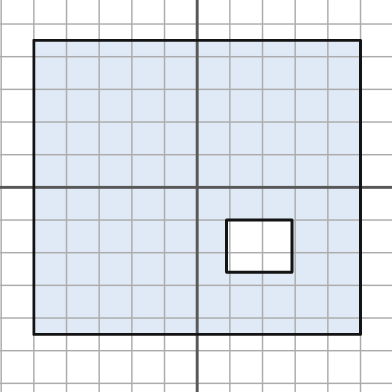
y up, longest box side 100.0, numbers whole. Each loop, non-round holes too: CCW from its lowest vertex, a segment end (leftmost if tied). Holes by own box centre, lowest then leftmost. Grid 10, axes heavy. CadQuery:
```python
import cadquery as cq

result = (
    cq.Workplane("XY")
    .moveTo(-50.0, -45.0)
    .lineTo(50.0, -45.0)
    .lineTo(50.0, 45.0)
    .lineTo(-50.0, 45.0)
    .close()
    .moveTo(9.0, -26.0)
    .lineTo(29.0, -26.0)
    .lineTo(29.0, -10.0)
    .lineTo(9.0, -10.0)
    .close()
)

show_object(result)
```